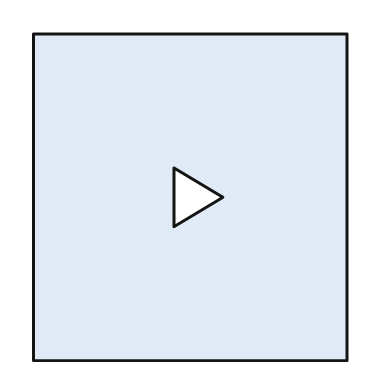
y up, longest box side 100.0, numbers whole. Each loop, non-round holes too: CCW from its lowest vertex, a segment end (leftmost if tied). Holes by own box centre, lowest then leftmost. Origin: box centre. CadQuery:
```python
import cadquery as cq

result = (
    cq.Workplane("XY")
    .moveTo(-48.0, -50.0)
    .lineTo(48.0, -50.0)
    .lineTo(48.0, 50.0)
    .lineTo(-48.0, 50.0)
    .close()
    .moveTo(-5.0, -9.0)
    .lineTo(10.0, 0.0)
    .lineTo(-5.0, 9.0)
    .close()
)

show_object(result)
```